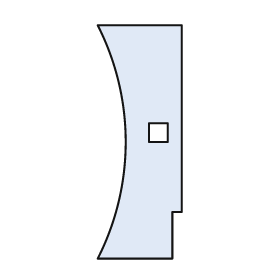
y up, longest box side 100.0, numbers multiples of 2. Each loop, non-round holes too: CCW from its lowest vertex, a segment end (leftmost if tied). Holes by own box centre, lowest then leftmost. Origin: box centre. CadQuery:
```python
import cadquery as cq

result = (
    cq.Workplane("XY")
    .moveTo(-18.0, -50.0)
    .lineTo(14.0, -50.0)
    .lineTo(14.0, -30.0)
    .lineTo(18.0, -30.0)
    .lineTo(18.0, 50.0)
    .lineTo(-18.0, 50.0)
    .threePointArc((-6.0, 0.0), (-18.0, -50.0))
    .close()
    .moveTo(4.0, 0.0)
    .lineTo(12.0, 0.0)
    .lineTo(12.0, 8.0)
    .lineTo(4.0, 8.0)
    .close()
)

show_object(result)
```